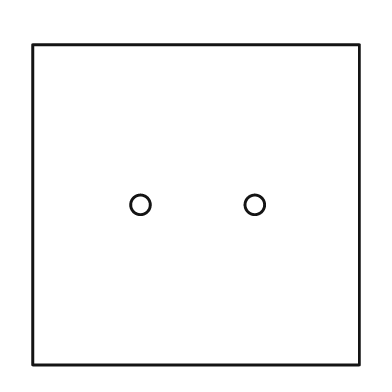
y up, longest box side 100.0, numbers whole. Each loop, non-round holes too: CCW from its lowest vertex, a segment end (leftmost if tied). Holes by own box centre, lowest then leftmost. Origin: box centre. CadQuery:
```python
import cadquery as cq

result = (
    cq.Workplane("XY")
    .moveTo(-50.0, -49.0)
    .lineTo(50.0, -49.0)
    .lineTo(50.0, 49.0)
    .lineTo(-50.0, 49.0)
    .close()
    .moveTo(-17.0, 0.0)
    .circle(3.0)
    .moveTo(18.0, 0.0)
    .circle(3.0)
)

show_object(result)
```